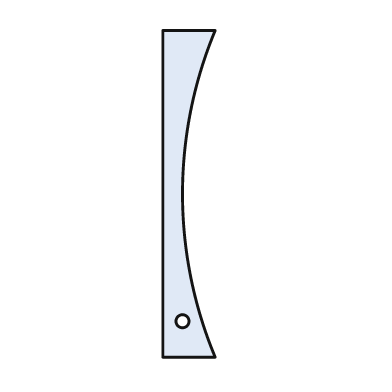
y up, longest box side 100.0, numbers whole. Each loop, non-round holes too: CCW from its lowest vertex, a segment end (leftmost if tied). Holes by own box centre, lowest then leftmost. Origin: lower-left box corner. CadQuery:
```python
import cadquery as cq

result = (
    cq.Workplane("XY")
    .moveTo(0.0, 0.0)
    .lineTo(16.0, 0.0)
    .threePointArc((6.0, 50.0), (16.0, 100.0))
    .lineTo(0.0, 100.0)
    .close()
    .moveTo(6.0, 11.0)
    .circle(2.0)
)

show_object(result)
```